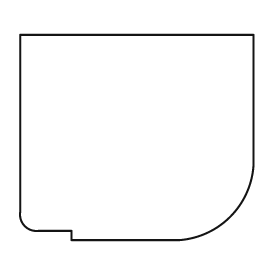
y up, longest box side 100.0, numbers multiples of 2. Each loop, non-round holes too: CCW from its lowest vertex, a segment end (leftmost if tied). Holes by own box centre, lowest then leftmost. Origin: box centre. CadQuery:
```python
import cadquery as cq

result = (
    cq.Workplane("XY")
    .moveTo(-28.0, -44.0)
    .lineTo(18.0, -44.0)
    .threePointArc((40.0, -34.0), (50.0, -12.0))
    .lineTo(50.0, 44.0)
    .lineTo(-50.0, 44.0)
    .lineTo(-50.0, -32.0)
    .threePointArc((-48.0, -38.0), (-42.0, -40.0))
    .lineTo(-28.0, -40.0)
    .close()
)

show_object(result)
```